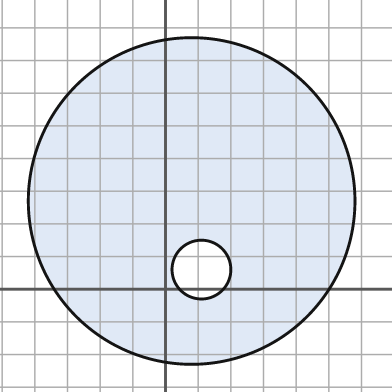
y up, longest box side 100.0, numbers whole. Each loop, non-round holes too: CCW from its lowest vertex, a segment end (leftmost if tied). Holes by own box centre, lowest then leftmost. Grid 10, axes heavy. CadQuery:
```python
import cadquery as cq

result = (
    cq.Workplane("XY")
    .moveTo(8.0, 27.0)
    .circle(50.0)
    .moveTo(11.0, 6.0)
    .circle(9.0)
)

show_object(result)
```